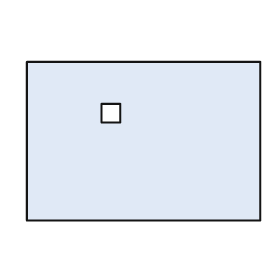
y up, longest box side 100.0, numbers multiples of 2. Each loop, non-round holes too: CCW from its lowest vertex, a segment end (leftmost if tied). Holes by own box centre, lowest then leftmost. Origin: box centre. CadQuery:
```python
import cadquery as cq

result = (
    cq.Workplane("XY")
    .moveTo(-50.0, -34.0)
    .lineTo(50.0, -34.0)
    .lineTo(50.0, 34.0)
    .lineTo(-50.0, 34.0)
    .close()
    .moveTo(-18.0, 8.0)
    .lineTo(-10.0, 8.0)
    .lineTo(-10.0, 16.0)
    .lineTo(-18.0, 16.0)
    .close()
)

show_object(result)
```